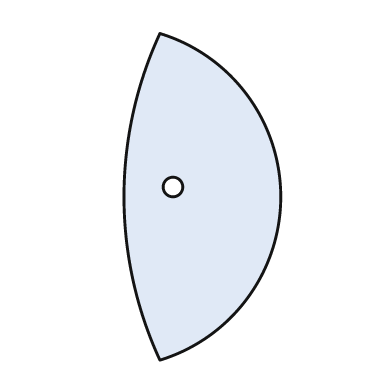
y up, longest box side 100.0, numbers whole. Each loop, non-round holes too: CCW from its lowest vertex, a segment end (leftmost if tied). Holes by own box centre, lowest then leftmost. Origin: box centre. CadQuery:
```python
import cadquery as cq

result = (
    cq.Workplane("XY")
    .moveTo(-13.0, -50.0)
    .threePointArc((24.0, 0.0), (-13.0, 50.0))
    .threePointArc((-24.0, 0.0), (-13.0, -50.0))
    .close()
    .moveTo(-9.0, 3.0)
    .circle(3.0)
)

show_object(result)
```